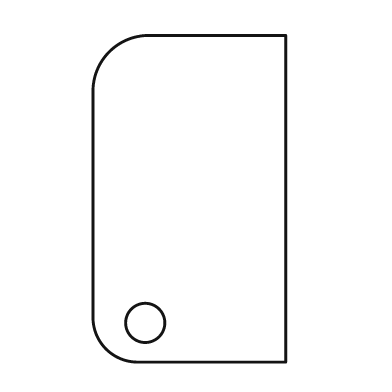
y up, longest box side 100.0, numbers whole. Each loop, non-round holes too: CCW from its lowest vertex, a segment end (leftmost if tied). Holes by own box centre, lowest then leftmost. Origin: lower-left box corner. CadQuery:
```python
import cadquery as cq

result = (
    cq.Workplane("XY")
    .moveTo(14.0, 0.0)
    .lineTo(59.0, 0.0)
    .lineTo(59.0, 100.0)
    .lineTo(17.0, 100.0)
    .threePointArc((5.0, 95.0), (0.0, 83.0))
    .lineTo(0.0, 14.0)
    .threePointArc((4.0, 4.0), (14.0, 0.0))
    .close()
    .moveTo(16.0, 12.0)
    .circle(6.0)
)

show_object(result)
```